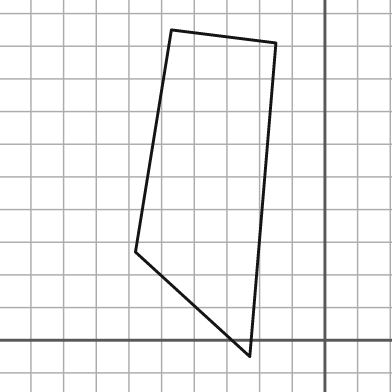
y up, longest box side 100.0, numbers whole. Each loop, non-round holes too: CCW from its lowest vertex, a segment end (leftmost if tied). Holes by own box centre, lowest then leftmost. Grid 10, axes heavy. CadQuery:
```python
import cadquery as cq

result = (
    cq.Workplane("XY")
    .moveTo(-23.0, -5.0)
    .lineTo(-15.0, 91.0)
    .lineTo(-47.0, 95.0)
    .lineTo(-58.0, 27.0)
    .close()
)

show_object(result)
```